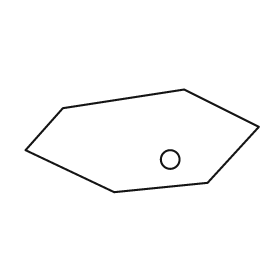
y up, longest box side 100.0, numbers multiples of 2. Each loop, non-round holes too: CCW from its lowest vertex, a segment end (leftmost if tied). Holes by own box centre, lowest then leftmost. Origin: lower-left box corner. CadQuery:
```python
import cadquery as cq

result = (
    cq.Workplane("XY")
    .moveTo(38.0, 0.0)
    .lineTo(78.0, 4.0)
    .lineTo(100.0, 28.0)
    .lineTo(68.0, 44.0)
    .lineTo(16.0, 36.0)
    .lineTo(0.0, 18.0)
    .close()
    .moveTo(62.0, 14.0)
    .circle(4.0)
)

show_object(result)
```